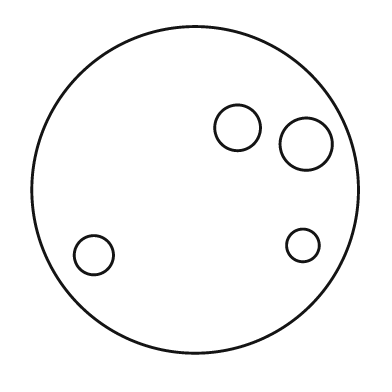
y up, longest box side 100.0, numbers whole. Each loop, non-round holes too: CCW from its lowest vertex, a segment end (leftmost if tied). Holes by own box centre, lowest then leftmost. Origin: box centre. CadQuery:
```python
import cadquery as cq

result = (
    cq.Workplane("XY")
    .moveTo(0.0, 0.0)
    .circle(50.0)
    .moveTo(-31.0, -20.0)
    .circle(6.0)
    .moveTo(33.0, -17.0)
    .circle(5.0)
    .moveTo(34.0, 14.0)
    .circle(8.0)
    .moveTo(13.0, 19.0)
    .circle(7.0)
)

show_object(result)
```